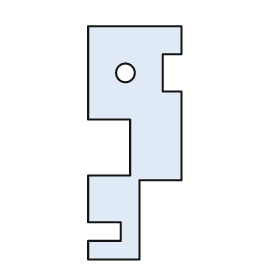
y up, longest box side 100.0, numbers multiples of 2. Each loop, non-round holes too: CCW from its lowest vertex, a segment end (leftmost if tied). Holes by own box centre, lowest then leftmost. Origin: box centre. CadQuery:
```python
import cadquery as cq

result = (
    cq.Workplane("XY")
    .moveTo(-20.0, -50.0)
    .lineTo(2.0, -50.0)
    .lineTo(2.0, -16.0)
    .lineTo(20.0, -16.0)
    .lineTo(20.0, 22.0)
    .lineTo(12.0, 22.0)
    .lineTo(12.0, 38.0)
    .lineTo(20.0, 38.0)
    .lineTo(20.0, 50.0)
    .lineTo(-20.0, 50.0)
    .lineTo(-20.0, 10.0)
    .lineTo(-2.0, 10.0)
    .lineTo(-2.0, -14.0)
    .lineTo(-20.0, -14.0)
    .lineTo(-20.0, -34.0)
    .lineTo(-6.0, -34.0)
    .lineTo(-6.0, -42.0)
    .lineTo(-20.0, -42.0)
    .close()
    .moveTo(-4.0, 30.0)
    .circle(4.0)
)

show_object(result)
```